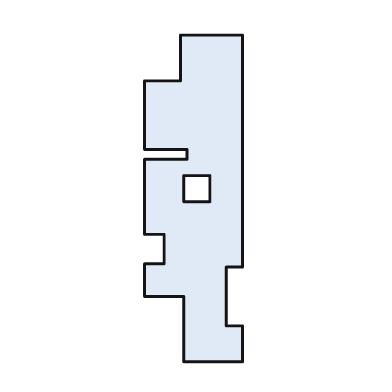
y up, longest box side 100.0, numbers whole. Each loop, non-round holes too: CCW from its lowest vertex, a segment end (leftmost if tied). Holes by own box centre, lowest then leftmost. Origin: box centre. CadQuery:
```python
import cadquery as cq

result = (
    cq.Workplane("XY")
    .moveTo(-3.0, -50.0)
    .lineTo(15.0, -50.0)
    .lineTo(15.0, -39.0)
    .lineTo(10.0, -39.0)
    .lineTo(10.0, -21.0)
    .lineTo(15.0, -21.0)
    .lineTo(15.0, 50.0)
    .lineTo(-4.0, 50.0)
    .lineTo(-4.0, 36.0)
    .lineTo(-15.0, 36.0)
    .lineTo(-15.0, 15.0)
    .lineTo(-2.0, 15.0)
    .lineTo(-2.0, 12.0)
    .lineTo(-15.0, 12.0)
    .lineTo(-15.0, -11.0)
    .lineTo(-9.0, -11.0)
    .lineTo(-9.0, -20.0)
    .lineTo(-15.0, -20.0)
    .lineTo(-15.0, -30.0)
    .lineTo(-3.0, -30.0)
    .close()
    .moveTo(-3.0, -1.0)
    .lineTo(5.0, -1.0)
    .lineTo(5.0, 7.0)
    .lineTo(-3.0, 7.0)
    .close()
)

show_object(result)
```